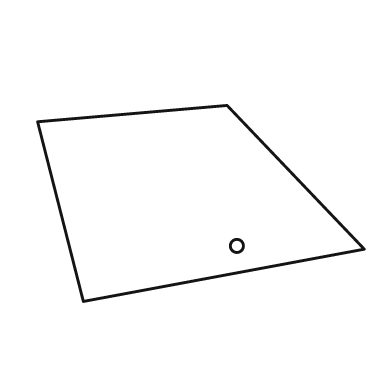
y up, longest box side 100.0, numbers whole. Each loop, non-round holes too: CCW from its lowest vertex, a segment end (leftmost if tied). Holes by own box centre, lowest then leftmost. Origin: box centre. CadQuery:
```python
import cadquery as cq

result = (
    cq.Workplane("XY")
    .moveTo(-36.0, -30.0)
    .lineTo(50.0, -14.0)
    .lineTo(8.0, 30.0)
    .lineTo(-50.0, 25.0)
    .close()
    .moveTo(11.0, -13.0)
    .circle(2.0)
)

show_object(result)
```